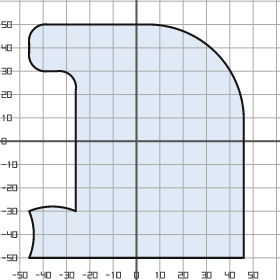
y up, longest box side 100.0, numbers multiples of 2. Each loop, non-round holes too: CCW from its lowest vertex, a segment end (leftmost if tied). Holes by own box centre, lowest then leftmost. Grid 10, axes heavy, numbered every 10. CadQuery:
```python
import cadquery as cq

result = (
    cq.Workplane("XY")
    .moveTo(-46.0, -50.0)
    .lineTo(46.0, -50.0)
    .lineTo(46.0, 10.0)
    .threePointArc((34.0, 38.0), (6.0, 50.0))
    .lineTo(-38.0, 50.0)
    .threePointArc((-44.0, 48.0), (-46.0, 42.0))
    .lineTo(-46.0, 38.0)
    .threePointArc((-44.0, 32.0), (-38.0, 30.0))
    .lineTo(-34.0, 30.0)
    .threePointArc((-28.0, 28.0), (-26.0, 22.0))
    .lineTo(-26.0, -30.0)
    .threePointArc((-36.0, -28.0), (-46.0, -30.0))
    .threePointArc((-44.0, -40.0), (-46.0, -50.0))
    .close()
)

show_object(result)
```